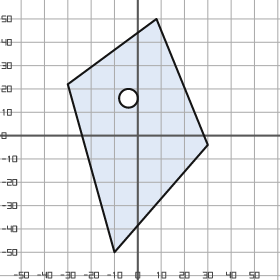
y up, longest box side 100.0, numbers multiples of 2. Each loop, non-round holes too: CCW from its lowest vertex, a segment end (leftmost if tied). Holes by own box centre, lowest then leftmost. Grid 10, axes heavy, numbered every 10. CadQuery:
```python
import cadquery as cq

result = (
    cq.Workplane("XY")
    .moveTo(-10.0, -50.0)
    .lineTo(30.0, -4.0)
    .lineTo(8.0, 50.0)
    .lineTo(-30.0, 22.0)
    .close()
    .moveTo(-4.0, 16.0)
    .circle(4.0)
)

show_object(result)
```